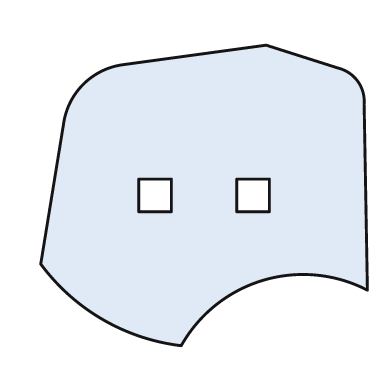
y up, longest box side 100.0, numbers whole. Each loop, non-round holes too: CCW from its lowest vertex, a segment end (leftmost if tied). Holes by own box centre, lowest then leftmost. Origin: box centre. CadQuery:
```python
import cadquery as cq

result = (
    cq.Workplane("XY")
    .moveTo(-7.0, -46.0)
    .threePointArc((18.0, -26.0), (50.0, -29.0))
    .lineTo(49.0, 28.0)
    .threePointArc((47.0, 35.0), (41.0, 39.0))
    .lineTo(19.0, 46.0)
    .lineTo(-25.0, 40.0)
    .threePointArc((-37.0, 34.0), (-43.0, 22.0))
    .lineTo(-50.0, -21.0)
    .threePointArc((-31.0, -38.0), (-7.0, -46.0))
    .close()
    .moveTo(-20.0, -5.0)
    .lineTo(-10.0, -5.0)
    .lineTo(-10.0, 5.0)
    .lineTo(-20.0, 5.0)
    .close()
    .moveTo(10.0, -5.0)
    .lineTo(20.0, -5.0)
    .lineTo(20.0, 5.0)
    .lineTo(10.0, 5.0)
    .close()
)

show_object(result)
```